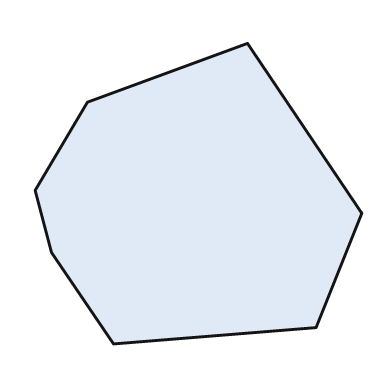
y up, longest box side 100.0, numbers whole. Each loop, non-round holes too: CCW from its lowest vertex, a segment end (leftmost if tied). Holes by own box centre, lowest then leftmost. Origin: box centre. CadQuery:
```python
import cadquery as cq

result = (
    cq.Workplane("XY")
    .moveTo(-26.0, -46.0)
    .lineTo(36.0, -41.0)
    .lineTo(50.0, -6.0)
    .lineTo(15.0, 46.0)
    .lineTo(-34.0, 28.0)
    .lineTo(-50.0, 1.0)
    .lineTo(-45.0, -18.0)
    .close()
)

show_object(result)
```